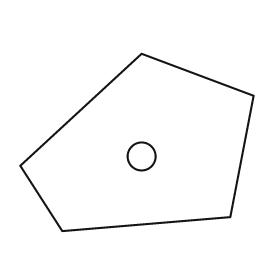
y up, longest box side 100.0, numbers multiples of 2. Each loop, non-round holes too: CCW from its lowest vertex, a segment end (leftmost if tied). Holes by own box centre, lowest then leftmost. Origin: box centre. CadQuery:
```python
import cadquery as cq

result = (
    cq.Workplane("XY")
    .moveTo(-32.0, -38.0)
    .lineTo(40.0, -32.0)
    .lineTo(50.0, 20.0)
    .lineTo(2.0, 38.0)
    .lineTo(-50.0, -10.0)
    .close()
    .moveTo(2.0, -6.0)
    .circle(6.0)
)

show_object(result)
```